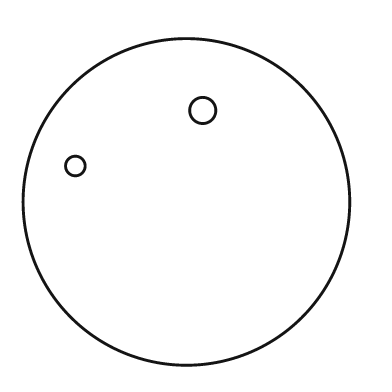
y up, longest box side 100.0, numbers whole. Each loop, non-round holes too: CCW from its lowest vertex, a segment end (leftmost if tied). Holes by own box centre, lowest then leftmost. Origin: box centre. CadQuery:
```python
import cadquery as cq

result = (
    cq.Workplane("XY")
    .moveTo(0.0, 0.0)
    .circle(50.0)
    .moveTo(-34.0, 11.0)
    .circle(3.0)
    .moveTo(5.0, 28.0)
    .circle(4.0)
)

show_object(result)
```